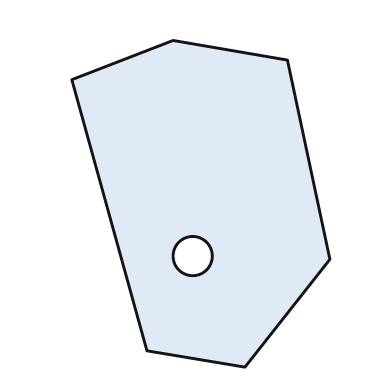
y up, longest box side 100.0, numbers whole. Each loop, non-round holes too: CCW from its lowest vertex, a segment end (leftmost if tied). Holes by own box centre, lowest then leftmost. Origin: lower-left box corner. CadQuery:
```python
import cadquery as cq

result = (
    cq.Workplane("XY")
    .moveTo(53.0, 0.0)
    .lineTo(79.0, 33.0)
    .lineTo(66.0, 94.0)
    .lineTo(31.0, 100.0)
    .lineTo(0.0, 88.0)
    .lineTo(23.0, 5.0)
    .close()
    .moveTo(37.0, 34.0)
    .circle(6.0)
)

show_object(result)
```